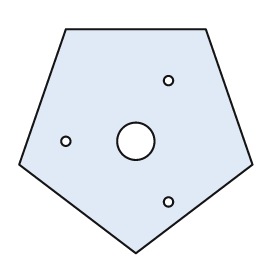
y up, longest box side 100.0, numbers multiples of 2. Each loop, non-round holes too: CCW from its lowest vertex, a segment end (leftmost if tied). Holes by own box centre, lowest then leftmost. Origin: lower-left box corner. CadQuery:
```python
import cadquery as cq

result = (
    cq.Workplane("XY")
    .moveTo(50.0, 0.0)
    .lineTo(100.0, 38.0)
    .lineTo(80.0, 96.0)
    .lineTo(20.0, 96.0)
    .lineTo(0.0, 38.0)
    .close()
    .moveTo(64.0, 22.0)
    .circle(2.0)
    .moveTo(20.0, 48.0)
    .circle(2.0)
    .moveTo(50.0, 48.0)
    .circle(8.0)
    .moveTo(64.0, 74.0)
    .circle(2.0)
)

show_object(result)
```